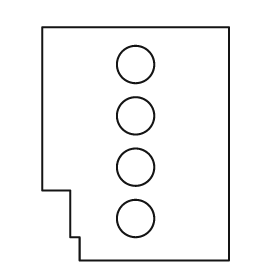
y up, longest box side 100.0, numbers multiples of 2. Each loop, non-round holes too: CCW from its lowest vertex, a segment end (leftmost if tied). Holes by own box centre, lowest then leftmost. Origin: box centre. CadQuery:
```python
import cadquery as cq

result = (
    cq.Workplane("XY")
    .moveTo(-24.0, -50.0)
    .lineTo(40.0, -50.0)
    .lineTo(40.0, 50.0)
    .lineTo(-40.0, 50.0)
    .lineTo(-40.0, -20.0)
    .lineTo(-28.0, -20.0)
    .lineTo(-28.0, -40.0)
    .lineTo(-24.0, -40.0)
    .close()
    .moveTo(0.0, -32.0)
    .circle(8.0)
    .moveTo(0.0, -10.0)
    .circle(8.0)
    .moveTo(0.0, 12.0)
    .circle(8.0)
    .moveTo(0.0, 34.0)
    .circle(8.0)
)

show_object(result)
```